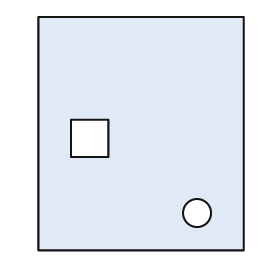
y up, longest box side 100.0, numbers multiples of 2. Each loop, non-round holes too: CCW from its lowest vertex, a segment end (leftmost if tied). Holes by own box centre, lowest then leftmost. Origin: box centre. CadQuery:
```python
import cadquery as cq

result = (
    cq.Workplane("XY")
    .moveTo(-44.0, -50.0)
    .lineTo(44.0, -50.0)
    .lineTo(44.0, 50.0)
    .lineTo(-44.0, 50.0)
    .close()
    .moveTo(24.0, -34.0)
    .circle(6.0)
    .moveTo(-30.0, -10.0)
    .lineTo(-14.0, -10.0)
    .lineTo(-14.0, 6.0)
    .lineTo(-30.0, 6.0)
    .close()
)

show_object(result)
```